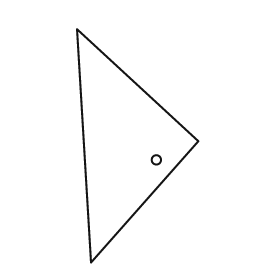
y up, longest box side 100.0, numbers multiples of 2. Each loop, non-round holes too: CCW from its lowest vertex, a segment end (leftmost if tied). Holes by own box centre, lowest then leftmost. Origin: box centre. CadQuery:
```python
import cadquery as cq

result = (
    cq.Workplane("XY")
    .moveTo(-20.0, -50.0)
    .lineTo(26.0, 2.0)
    .lineTo(-26.0, 50.0)
    .close()
    .moveTo(8.0, -6.0)
    .circle(2.0)
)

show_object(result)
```